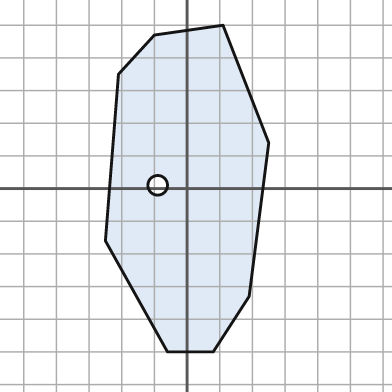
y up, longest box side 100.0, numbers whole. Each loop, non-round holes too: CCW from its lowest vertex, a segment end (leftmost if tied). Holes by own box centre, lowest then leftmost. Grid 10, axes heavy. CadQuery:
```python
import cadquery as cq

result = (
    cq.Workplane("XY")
    .moveTo(-6.0, -50.0)
    .lineTo(8.0, -50.0)
    .lineTo(19.0, -33.0)
    .lineTo(25.0, 14.0)
    .lineTo(11.0, 50.0)
    .lineTo(-10.0, 47.0)
    .lineTo(-21.0, 35.0)
    .lineTo(-25.0, -16.0)
    .close()
    .moveTo(-9.0, 1.0)
    .circle(3.0)
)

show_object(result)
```